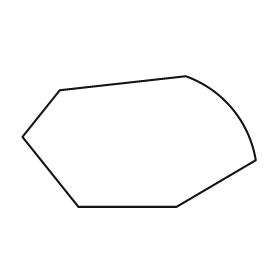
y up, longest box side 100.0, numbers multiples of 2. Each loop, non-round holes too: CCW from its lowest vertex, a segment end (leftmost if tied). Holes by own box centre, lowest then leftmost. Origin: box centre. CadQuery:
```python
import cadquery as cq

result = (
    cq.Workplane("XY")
    .moveTo(-26.0, -28.0)
    .lineTo(16.0, -28.0)
    .lineTo(50.0, -8.0)
    .threePointArc((40.0, 14.0), (20.0, 28.0))
    .lineTo(-34.0, 22.0)
    .lineTo(-50.0, 2.0)
    .close()
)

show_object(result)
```